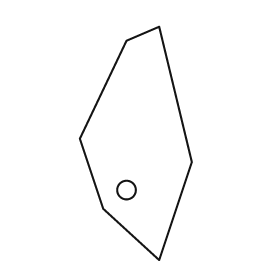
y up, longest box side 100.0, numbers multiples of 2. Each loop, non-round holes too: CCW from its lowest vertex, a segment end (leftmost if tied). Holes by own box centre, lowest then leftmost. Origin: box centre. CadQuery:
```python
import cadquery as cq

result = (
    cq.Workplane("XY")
    .moveTo(10.0, -50.0)
    .lineTo(24.0, -8.0)
    .lineTo(10.0, 50.0)
    .lineTo(-4.0, 44.0)
    .lineTo(-24.0, 2.0)
    .lineTo(-14.0, -28.0)
    .close()
    .moveTo(-4.0, -20.0)
    .circle(4.0)
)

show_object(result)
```